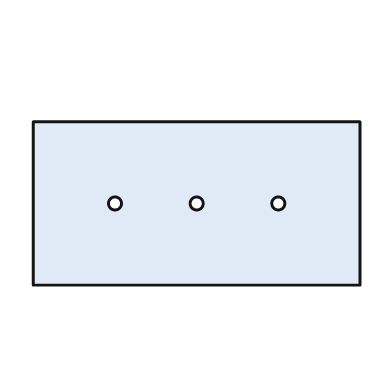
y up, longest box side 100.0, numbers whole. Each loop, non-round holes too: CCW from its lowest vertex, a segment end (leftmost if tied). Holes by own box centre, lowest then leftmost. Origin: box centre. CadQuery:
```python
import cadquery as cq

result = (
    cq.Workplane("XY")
    .moveTo(-50.0, -25.0)
    .lineTo(50.0, -25.0)
    .lineTo(50.0, 25.0)
    .lineTo(-50.0, 25.0)
    .close()
    .moveTo(-25.0, 0.0)
    .circle(2.0)
    .moveTo(0.0, 0.0)
    .circle(2.0)
    .moveTo(25.0, 0.0)
    .circle(2.0)
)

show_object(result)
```